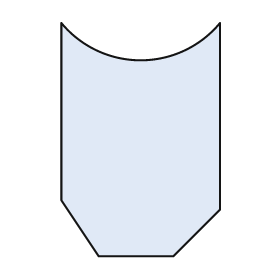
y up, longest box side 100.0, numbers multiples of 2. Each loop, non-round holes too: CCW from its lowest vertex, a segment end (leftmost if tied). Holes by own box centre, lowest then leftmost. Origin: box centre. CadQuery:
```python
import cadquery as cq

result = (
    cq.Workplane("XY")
    .moveTo(-18.0, -50.0)
    .lineTo(14.0, -50.0)
    .lineTo(34.0, -30.0)
    .lineTo(34.0, 50.0)
    .threePointArc((0.0, 34.0), (-34.0, 50.0))
    .lineTo(-34.0, -26.0)
    .close()
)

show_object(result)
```